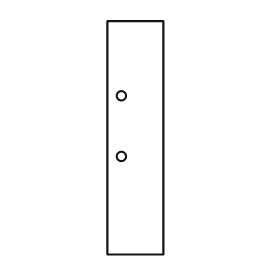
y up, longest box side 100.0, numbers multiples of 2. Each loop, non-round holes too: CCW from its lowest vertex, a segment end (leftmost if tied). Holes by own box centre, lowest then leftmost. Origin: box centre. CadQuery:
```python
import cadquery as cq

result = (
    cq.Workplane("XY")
    .moveTo(-12.0, -50.0)
    .lineTo(12.0, -50.0)
    .lineTo(12.0, 50.0)
    .lineTo(-12.0, 50.0)
    .close()
    .moveTo(-6.0, -8.0)
    .circle(2.0)
    .moveTo(-6.0, 18.0)
    .circle(2.0)
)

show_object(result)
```